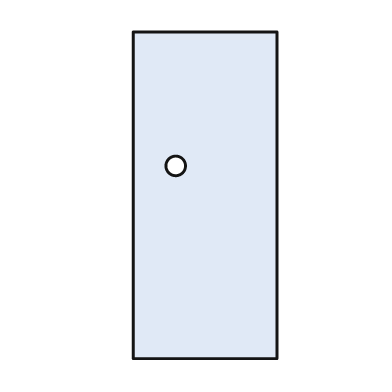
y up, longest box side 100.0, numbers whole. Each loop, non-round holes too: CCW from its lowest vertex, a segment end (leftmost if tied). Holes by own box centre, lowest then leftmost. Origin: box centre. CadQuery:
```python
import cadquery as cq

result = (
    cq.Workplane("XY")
    .moveTo(-22.0, -50.0)
    .lineTo(22.0, -50.0)
    .lineTo(22.0, 50.0)
    .lineTo(-22.0, 50.0)
    .close()
    .moveTo(-9.0, 9.0)
    .circle(3.0)
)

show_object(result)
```